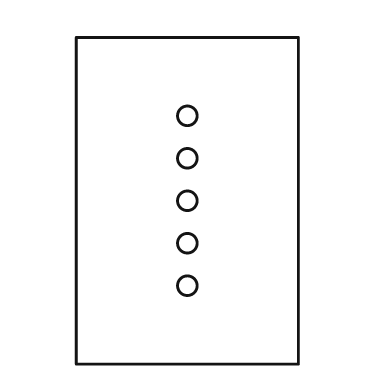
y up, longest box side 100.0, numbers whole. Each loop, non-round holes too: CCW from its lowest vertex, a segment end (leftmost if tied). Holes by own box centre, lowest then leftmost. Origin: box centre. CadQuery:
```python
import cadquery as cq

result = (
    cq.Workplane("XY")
    .moveTo(-34.0, -50.0)
    .lineTo(34.0, -50.0)
    .lineTo(34.0, 50.0)
    .lineTo(-34.0, 50.0)
    .close()
    .moveTo(0.0, -26.0)
    .circle(3.0)
    .moveTo(0.0, -13.0)
    .circle(3.0)
    .moveTo(0.0, 0.0)
    .circle(3.0)
    .moveTo(0.0, 13.0)
    .circle(3.0)
    .moveTo(0.0, 26.0)
    .circle(3.0)
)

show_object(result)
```